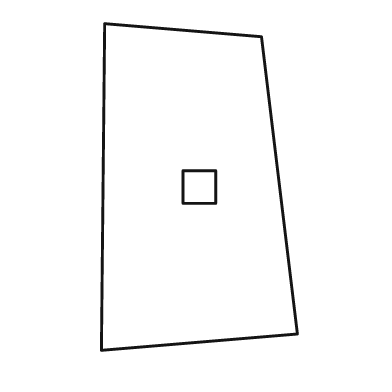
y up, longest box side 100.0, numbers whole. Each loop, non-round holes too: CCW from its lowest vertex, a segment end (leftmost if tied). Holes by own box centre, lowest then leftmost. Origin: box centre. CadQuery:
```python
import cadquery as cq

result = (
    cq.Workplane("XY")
    .moveTo(-30.0, -50.0)
    .lineTo(30.0, -45.0)
    .lineTo(19.0, 46.0)
    .lineTo(-29.0, 50.0)
    .close()
    .moveTo(-5.0, -5.0)
    .lineTo(5.0, -5.0)
    .lineTo(5.0, 5.0)
    .lineTo(-5.0, 5.0)
    .close()
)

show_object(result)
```